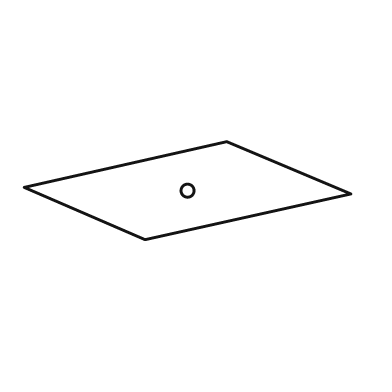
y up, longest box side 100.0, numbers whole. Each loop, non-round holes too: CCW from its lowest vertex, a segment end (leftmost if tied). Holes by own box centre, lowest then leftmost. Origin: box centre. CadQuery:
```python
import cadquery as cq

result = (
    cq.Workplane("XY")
    .moveTo(-13.0, -15.0)
    .lineTo(50.0, -1.0)
    .lineTo(12.0, 15.0)
    .lineTo(-50.0, 1.0)
    .close()
    .moveTo(0.0, 0.0)
    .circle(2.0)
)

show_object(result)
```